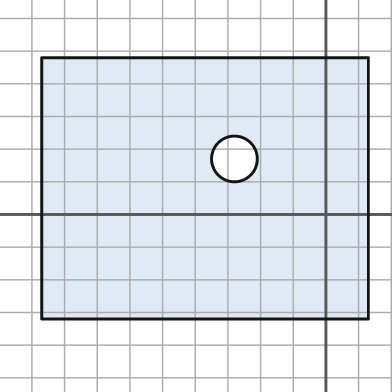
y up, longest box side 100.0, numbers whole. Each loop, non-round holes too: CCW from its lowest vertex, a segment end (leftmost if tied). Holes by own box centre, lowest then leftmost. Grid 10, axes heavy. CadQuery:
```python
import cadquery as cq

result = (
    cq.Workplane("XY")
    .moveTo(-87.0, -32.0)
    .lineTo(13.0, -32.0)
    .lineTo(13.0, 48.0)
    .lineTo(-87.0, 48.0)
    .close()
    .moveTo(-28.0, 17.0)
    .circle(7.0)
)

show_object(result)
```